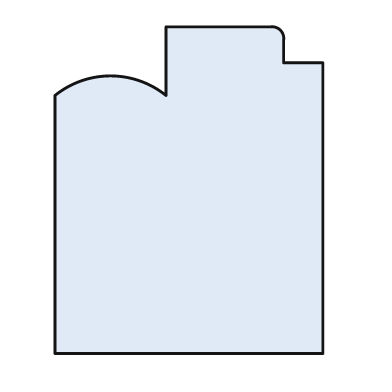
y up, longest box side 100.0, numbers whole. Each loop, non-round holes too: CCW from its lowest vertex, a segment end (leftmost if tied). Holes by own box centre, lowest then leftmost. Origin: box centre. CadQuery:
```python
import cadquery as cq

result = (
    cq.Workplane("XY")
    .moveTo(-41.0, -50.0)
    .lineTo(41.0, -50.0)
    .lineTo(41.0, 39.0)
    .lineTo(29.0, 39.0)
    .lineTo(29.0, 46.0)
    .threePointArc((28.0, 49.0), (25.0, 50.0))
    .lineTo(-7.0, 50.0)
    .lineTo(-7.0, 29.0)
    .threePointArc((-24.0, 35.0), (-41.0, 29.0))
    .close()
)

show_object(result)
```